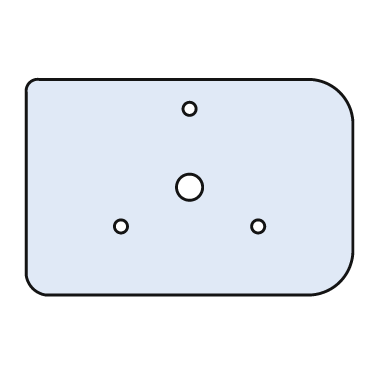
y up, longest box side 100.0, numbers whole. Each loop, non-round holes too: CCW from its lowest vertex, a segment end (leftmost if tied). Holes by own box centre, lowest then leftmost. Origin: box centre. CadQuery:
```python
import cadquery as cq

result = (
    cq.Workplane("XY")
    .moveTo(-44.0, -33.0)
    .lineTo(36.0, -33.0)
    .threePointArc((46.0, -29.0), (50.0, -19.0))
    .lineTo(50.0, 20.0)
    .threePointArc((46.0, 29.0), (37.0, 33.0))
    .lineTo(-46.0, 33.0)
    .threePointArc((-49.0, 32.0), (-50.0, 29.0))
    .lineTo(-50.0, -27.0)
    .threePointArc((-48.0, -31.0), (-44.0, -33.0))
    .close()
    .moveTo(-21.0, -12.0)
    .circle(2.0)
    .moveTo(21.0, -12.0)
    .circle(2.0)
    .moveTo(0.0, 0.0)
    .circle(4.0)
    .moveTo(0.0, 24.0)
    .circle(2.0)
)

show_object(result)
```